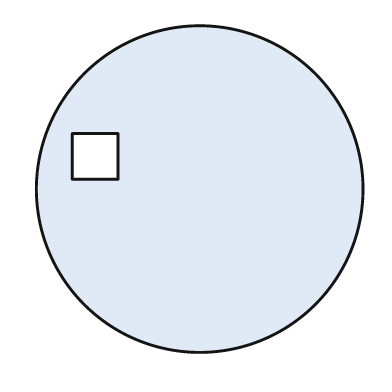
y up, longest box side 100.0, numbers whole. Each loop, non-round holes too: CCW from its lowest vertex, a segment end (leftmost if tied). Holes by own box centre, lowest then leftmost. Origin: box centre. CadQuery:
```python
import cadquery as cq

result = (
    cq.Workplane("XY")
    .moveTo(0.0, 0.0)
    .circle(50.0)
    .moveTo(-39.0, 3.0)
    .lineTo(-25.0, 3.0)
    .lineTo(-25.0, 17.0)
    .lineTo(-39.0, 17.0)
    .close()
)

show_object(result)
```